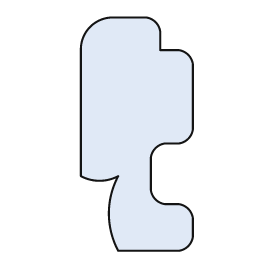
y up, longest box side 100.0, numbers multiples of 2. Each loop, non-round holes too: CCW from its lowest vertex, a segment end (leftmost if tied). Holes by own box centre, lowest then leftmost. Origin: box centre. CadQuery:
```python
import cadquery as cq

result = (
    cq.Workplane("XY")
    .moveTo(-8.0, -50.0)
    .lineTo(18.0, -50.0)
    .threePointArc((22.0, -48.0), (24.0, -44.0))
    .lineTo(24.0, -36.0)
    .threePointArc((22.0, -32.0), (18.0, -30.0))
    .lineTo(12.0, -30.0)
    .threePointArc((8.0, -28.0), (6.0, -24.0))
    .lineTo(6.0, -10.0)
    .threePointArc((8.0, -6.0), (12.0, -4.0))
    .lineTo(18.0, -4.0)
    .threePointArc((22.0, -2.0), (24.0, 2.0))
    .lineTo(24.0, 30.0)
    .threePointArc((22.0, 34.0), (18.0, 36.0))
    .lineTo(10.0, 36.0)
    .lineTo(10.0, 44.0)
    .threePointArc((8.0, 48.0), (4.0, 50.0))
    .lineTo(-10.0, 50.0)
    .threePointArc((-20.0, 46.0), (-24.0, 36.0))
    .lineTo(-24.0, -18.0)
    .threePointArc((-16.0, -20.0), (-8.0, -18.0))
    .threePointArc((-12.0, -34.0), (-8.0, -50.0))
    .close()
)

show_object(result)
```